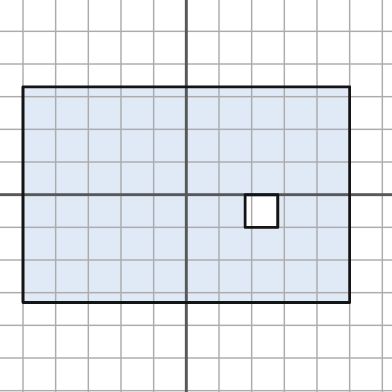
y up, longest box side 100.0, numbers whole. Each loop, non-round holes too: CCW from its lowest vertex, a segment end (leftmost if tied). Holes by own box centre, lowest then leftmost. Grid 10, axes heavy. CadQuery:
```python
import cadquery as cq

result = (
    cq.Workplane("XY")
    .moveTo(-50.0, -33.0)
    .lineTo(50.0, -33.0)
    .lineTo(50.0, 33.0)
    .lineTo(-50.0, 33.0)
    .close()
    .moveTo(18.0, -10.0)
    .lineTo(28.0, -10.0)
    .lineTo(28.0, 0.0)
    .lineTo(18.0, 0.0)
    .close()
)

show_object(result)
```